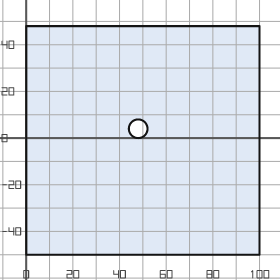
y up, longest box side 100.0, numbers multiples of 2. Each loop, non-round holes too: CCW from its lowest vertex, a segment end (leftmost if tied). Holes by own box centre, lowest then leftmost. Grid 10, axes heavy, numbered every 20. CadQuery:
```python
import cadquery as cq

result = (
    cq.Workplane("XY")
    .moveTo(0.0, -50.0)
    .lineTo(100.0, -50.0)
    .lineTo(100.0, 48.0)
    .lineTo(0.0, 48.0)
    .close()
    .moveTo(48.0, 4.0)
    .circle(4.0)
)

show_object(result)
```